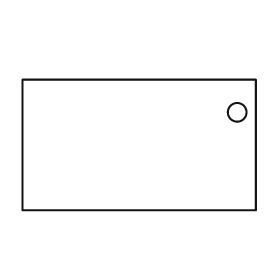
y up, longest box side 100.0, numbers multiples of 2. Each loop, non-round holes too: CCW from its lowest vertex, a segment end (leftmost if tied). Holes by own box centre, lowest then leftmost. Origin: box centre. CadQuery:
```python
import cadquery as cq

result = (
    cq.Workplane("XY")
    .moveTo(-50.0, -28.0)
    .lineTo(50.0, -28.0)
    .lineTo(50.0, 28.0)
    .lineTo(-50.0, 28.0)
    .close()
    .moveTo(42.0, 14.0)
    .circle(4.0)
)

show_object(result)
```